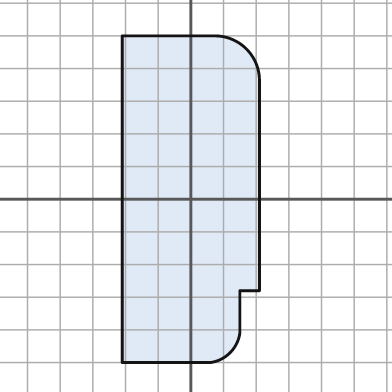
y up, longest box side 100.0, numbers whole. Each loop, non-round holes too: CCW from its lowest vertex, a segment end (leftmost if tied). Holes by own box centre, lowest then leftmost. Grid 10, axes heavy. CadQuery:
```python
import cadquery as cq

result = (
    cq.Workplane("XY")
    .moveTo(-21.0, -50.0)
    .lineTo(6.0, -50.0)
    .threePointArc((12.0, -47.0), (15.0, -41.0))
    .lineTo(15.0, -28.0)
    .lineTo(21.0, -28.0)
    .lineTo(21.0, 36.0)
    .threePointArc((17.0, 46.0), (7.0, 50.0))
    .lineTo(-21.0, 50.0)
    .close()
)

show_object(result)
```